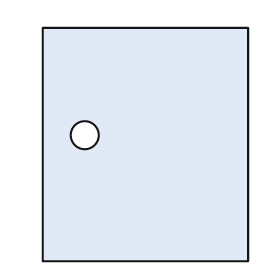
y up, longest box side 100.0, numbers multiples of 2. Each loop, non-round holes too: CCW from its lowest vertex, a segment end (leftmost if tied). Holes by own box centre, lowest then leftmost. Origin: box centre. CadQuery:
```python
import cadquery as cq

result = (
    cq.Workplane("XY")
    .moveTo(-44.0, -50.0)
    .lineTo(44.0, -50.0)
    .lineTo(44.0, 50.0)
    .lineTo(-44.0, 50.0)
    .close()
    .moveTo(-26.0, 4.0)
    .circle(6.0)
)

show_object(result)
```